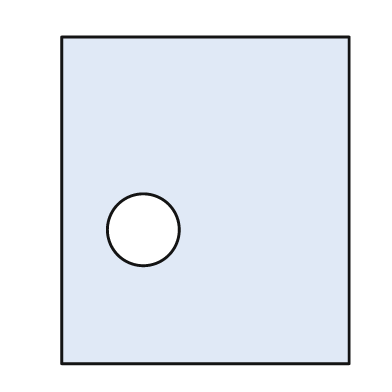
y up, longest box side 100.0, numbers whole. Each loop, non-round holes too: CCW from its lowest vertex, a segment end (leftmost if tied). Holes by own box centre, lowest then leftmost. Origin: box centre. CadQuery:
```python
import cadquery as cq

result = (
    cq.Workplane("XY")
    .moveTo(-44.0, -50.0)
    .lineTo(44.0, -50.0)
    .lineTo(44.0, 50.0)
    .lineTo(-44.0, 50.0)
    .close()
    .moveTo(-19.0, -9.0)
    .circle(11.0)
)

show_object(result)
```